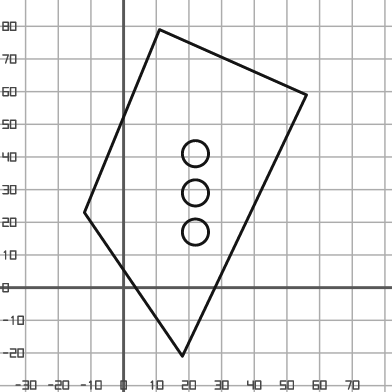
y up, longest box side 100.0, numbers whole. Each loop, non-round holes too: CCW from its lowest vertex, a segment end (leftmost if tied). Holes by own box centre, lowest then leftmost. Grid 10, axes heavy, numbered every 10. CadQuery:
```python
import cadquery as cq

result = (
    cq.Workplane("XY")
    .moveTo(18.0, -21.0)
    .lineTo(56.0, 59.0)
    .lineTo(11.0, 79.0)
    .lineTo(-12.0, 23.0)
    .close()
    .moveTo(22.0, 17.0)
    .circle(4.0)
    .moveTo(22.0, 29.0)
    .circle(4.0)
    .moveTo(22.0, 41.0)
    .circle(4.0)
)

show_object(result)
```